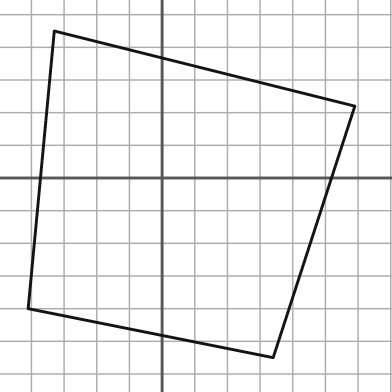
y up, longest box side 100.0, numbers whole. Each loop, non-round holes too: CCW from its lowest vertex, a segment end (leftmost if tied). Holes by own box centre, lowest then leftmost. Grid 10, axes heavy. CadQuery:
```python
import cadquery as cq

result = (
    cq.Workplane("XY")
    .moveTo(34.0, -55.0)
    .lineTo(59.0, 22.0)
    .lineTo(-33.0, 45.0)
    .lineTo(-41.0, -40.0)
    .close()
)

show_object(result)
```